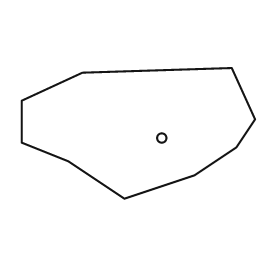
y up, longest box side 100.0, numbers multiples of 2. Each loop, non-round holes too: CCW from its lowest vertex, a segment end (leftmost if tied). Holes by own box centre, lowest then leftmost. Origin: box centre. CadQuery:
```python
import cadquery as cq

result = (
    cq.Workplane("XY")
    .moveTo(-6.0, -28.0)
    .lineTo(24.0, -18.0)
    .lineTo(42.0, -6.0)
    .lineTo(50.0, 6.0)
    .lineTo(40.0, 28.0)
    .lineTo(-24.0, 26.0)
    .lineTo(-50.0, 14.0)
    .lineTo(-50.0, -4.0)
    .lineTo(-30.0, -12.0)
    .close()
    .moveTo(10.0, -2.0)
    .circle(2.0)
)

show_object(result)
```